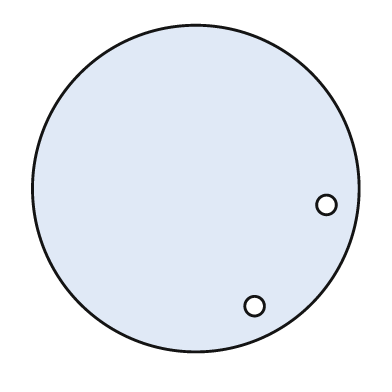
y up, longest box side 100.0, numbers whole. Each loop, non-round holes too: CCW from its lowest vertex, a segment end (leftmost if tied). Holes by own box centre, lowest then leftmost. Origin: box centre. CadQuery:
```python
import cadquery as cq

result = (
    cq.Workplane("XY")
    .moveTo(0.0, 0.0)
    .circle(50.0)
    .moveTo(18.0, -36.0)
    .circle(3.0)
    .moveTo(40.0, -5.0)
    .circle(3.0)
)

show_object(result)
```